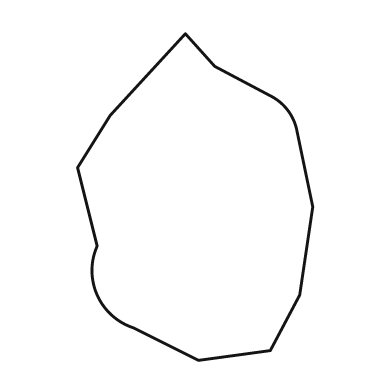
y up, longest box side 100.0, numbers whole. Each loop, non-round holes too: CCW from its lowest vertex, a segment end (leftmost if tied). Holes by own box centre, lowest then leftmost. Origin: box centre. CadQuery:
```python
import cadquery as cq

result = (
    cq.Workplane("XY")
    .moveTo(1.0, -50.0)
    .lineTo(23.0, -47.0)
    .lineTo(32.0, -30.0)
    .lineTo(36.0, -3.0)
    .lineTo(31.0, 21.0)
    .threePointArc((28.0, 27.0), (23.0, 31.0))
    .lineTo(6.0, 40.0)
    .lineTo(-3.0, 50.0)
    .lineTo(-26.0, 25.0)
    .lineTo(-36.0, 9.0)
    .lineTo(-30.0, -15.0)
    .threePointArc((-30.0, -30.0), (-19.0, -40.0))
    .close()
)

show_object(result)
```